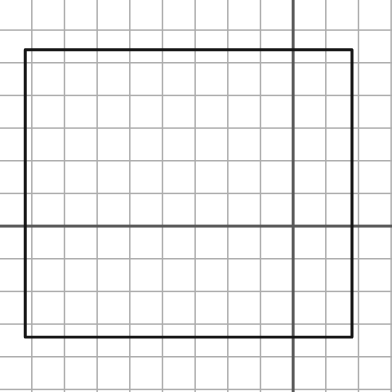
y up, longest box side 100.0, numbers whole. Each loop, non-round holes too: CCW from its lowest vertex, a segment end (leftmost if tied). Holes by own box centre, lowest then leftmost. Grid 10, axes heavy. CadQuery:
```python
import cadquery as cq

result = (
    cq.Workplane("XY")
    .moveTo(-82.0, -34.0)
    .lineTo(18.0, -34.0)
    .lineTo(18.0, 54.0)
    .lineTo(-82.0, 54.0)
    .close()
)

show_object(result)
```